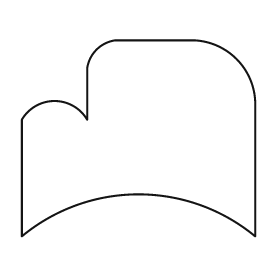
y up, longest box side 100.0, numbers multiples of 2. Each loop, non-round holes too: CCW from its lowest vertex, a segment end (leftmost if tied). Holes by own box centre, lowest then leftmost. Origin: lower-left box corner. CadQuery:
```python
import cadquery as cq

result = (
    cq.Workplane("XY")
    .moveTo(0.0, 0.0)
    .threePointArc((50.0, 18.0), (100.0, 0.0))
    .lineTo(100.0, 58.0)
    .threePointArc((92.0, 76.0), (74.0, 84.0))
    .lineTo(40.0, 84.0)
    .threePointArc((32.0, 80.0), (28.0, 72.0))
    .lineTo(28.0, 50.0)
    .threePointArc((14.0, 58.0), (0.0, 50.0))
    .close()
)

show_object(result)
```